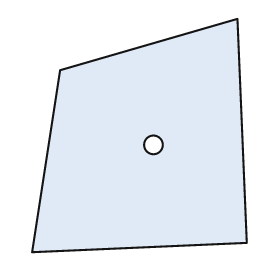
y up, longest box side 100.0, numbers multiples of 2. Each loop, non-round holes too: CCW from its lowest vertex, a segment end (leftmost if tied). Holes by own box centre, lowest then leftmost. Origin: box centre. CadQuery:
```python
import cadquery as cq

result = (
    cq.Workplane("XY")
    .moveTo(-46.0, -50.0)
    .lineTo(46.0, -46.0)
    .lineTo(42.0, 50.0)
    .lineTo(-34.0, 28.0)
    .close()
    .moveTo(6.0, -4.0)
    .circle(4.0)
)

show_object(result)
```